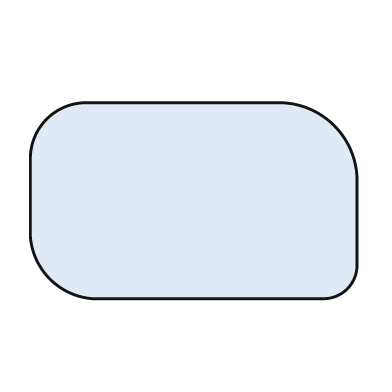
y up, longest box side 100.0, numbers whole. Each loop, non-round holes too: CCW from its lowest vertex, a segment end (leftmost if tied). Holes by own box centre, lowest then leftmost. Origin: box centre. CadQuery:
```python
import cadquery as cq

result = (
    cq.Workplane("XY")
    .moveTo(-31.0, -30.0)
    .lineTo(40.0, -30.0)
    .threePointArc((47.0, -27.0), (50.0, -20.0))
    .lineTo(50.0, 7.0)
    .threePointArc((43.0, 23.0), (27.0, 30.0))
    .lineTo(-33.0, 30.0)
    .threePointArc((-45.0, 25.0), (-50.0, 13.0))
    .lineTo(-50.0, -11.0)
    .threePointArc((-44.0, -24.0), (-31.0, -30.0))
    .close()
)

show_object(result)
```